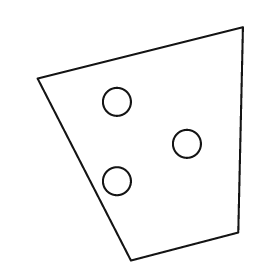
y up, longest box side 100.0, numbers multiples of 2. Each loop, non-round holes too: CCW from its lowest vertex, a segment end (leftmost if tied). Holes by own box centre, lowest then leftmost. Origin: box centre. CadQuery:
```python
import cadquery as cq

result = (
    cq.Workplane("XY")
    .moveTo(-4.0, -50.0)
    .lineTo(42.0, -38.0)
    .lineTo(44.0, 50.0)
    .lineTo(-44.0, 28.0)
    .close()
    .moveTo(-10.0, -16.0)
    .circle(6.0)
    .moveTo(20.0, 0.0)
    .circle(6.0)
    .moveTo(-10.0, 18.0)
    .circle(6.0)
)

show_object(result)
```